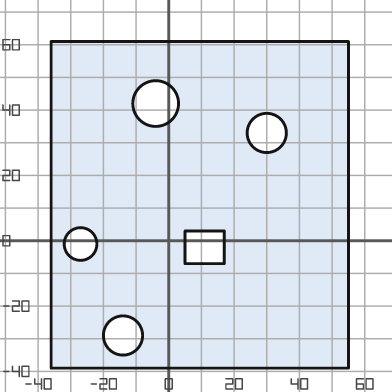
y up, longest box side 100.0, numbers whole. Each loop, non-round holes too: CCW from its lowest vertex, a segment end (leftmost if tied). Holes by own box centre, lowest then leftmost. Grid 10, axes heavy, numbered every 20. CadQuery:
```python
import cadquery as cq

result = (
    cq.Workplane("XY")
    .moveTo(-36.0, -39.0)
    .lineTo(55.0, -39.0)
    .lineTo(55.0, 61.0)
    .lineTo(-36.0, 61.0)
    .close()
    .moveTo(-14.0, -29.0)
    .circle(6.0)
    .moveTo(5.0, -7.0)
    .lineTo(17.0, -7.0)
    .lineTo(17.0, 3.0)
    .lineTo(5.0, 3.0)
    .close()
    .moveTo(-27.0, -1.0)
    .circle(5.0)
    .moveTo(30.0, 33.0)
    .circle(6.0)
    .moveTo(-4.0, 42.0)
    .circle(7.0)
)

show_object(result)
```